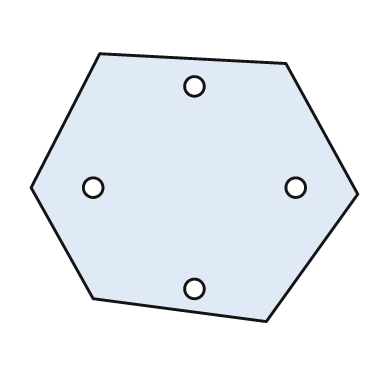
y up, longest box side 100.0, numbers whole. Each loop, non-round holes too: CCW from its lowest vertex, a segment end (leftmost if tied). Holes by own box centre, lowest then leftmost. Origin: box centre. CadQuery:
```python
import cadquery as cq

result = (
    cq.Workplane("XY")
    .moveTo(22.0, -41.0)
    .lineTo(50.0, -2.0)
    .lineTo(28.0, 38.0)
    .lineTo(-29.0, 41.0)
    .lineTo(-50.0, 0.0)
    .lineTo(-31.0, -34.0)
    .close()
    .moveTo(0.0, -31.0)
    .circle(3.0)
    .moveTo(-31.0, 0.0)
    .circle(3.0)
    .moveTo(31.0, 0.0)
    .circle(3.0)
    .moveTo(0.0, 31.0)
    .circle(3.0)
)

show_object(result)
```